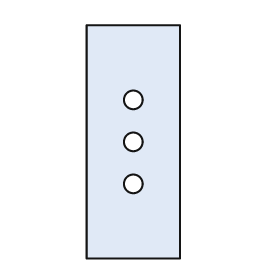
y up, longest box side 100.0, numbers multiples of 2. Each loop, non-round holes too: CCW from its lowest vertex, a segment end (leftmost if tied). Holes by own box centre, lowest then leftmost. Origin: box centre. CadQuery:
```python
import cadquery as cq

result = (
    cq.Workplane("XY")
    .moveTo(-20.0, -50.0)
    .lineTo(20.0, -50.0)
    .lineTo(20.0, 50.0)
    .lineTo(-20.0, 50.0)
    .close()
    .moveTo(0.0, -18.0)
    .circle(4.0)
    .moveTo(0.0, 0.0)
    .circle(4.0)
    .moveTo(0.0, 18.0)
    .circle(4.0)
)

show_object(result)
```